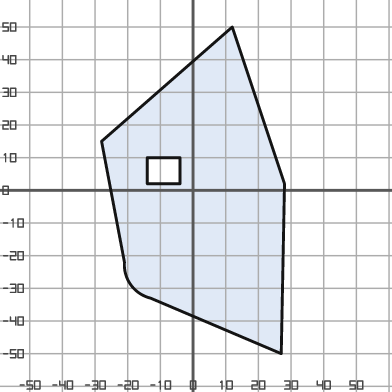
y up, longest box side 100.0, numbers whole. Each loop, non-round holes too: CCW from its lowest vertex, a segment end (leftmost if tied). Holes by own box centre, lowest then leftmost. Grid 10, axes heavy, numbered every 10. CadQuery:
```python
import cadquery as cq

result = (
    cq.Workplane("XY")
    .moveTo(27.0, -50.0)
    .lineTo(28.0, 2.0)
    .lineTo(12.0, 50.0)
    .lineTo(-28.0, 15.0)
    .lineTo(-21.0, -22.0)
    .threePointArc((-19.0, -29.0), (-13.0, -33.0))
    .close()
    .moveTo(-14.0, 2.0)
    .lineTo(-4.0, 2.0)
    .lineTo(-4.0, 10.0)
    .lineTo(-14.0, 10.0)
    .close()
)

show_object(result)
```